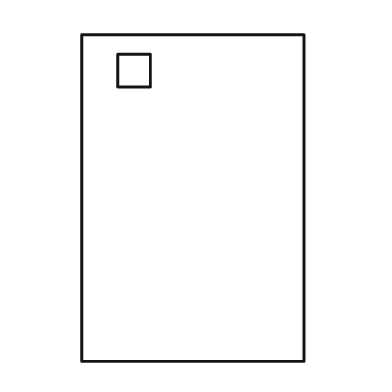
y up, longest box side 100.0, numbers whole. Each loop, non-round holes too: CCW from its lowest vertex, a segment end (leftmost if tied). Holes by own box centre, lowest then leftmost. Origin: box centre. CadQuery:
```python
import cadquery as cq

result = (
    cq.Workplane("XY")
    .moveTo(-34.0, -50.0)
    .lineTo(34.0, -50.0)
    .lineTo(34.0, 50.0)
    .lineTo(-34.0, 50.0)
    .close()
    .moveTo(-23.0, 34.0)
    .lineTo(-13.0, 34.0)
    .lineTo(-13.0, 44.0)
    .lineTo(-23.0, 44.0)
    .close()
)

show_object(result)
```